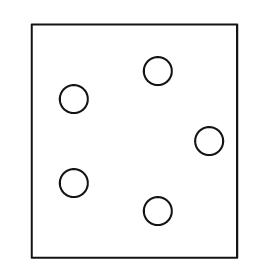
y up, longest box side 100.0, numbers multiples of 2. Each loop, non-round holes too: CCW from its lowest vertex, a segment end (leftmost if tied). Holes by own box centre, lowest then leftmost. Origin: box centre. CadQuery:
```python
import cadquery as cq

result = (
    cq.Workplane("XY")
    .moveTo(-44.0, -50.0)
    .lineTo(44.0, -50.0)
    .lineTo(44.0, 50.0)
    .lineTo(-44.0, 50.0)
    .close()
    .moveTo(10.0, -30.0)
    .circle(6.0)
    .moveTo(-26.0, -18.0)
    .circle(6.0)
    .moveTo(32.0, 0.0)
    .circle(6.0)
    .moveTo(-26.0, 18.0)
    .circle(6.0)
    .moveTo(10.0, 30.0)
    .circle(6.0)
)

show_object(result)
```